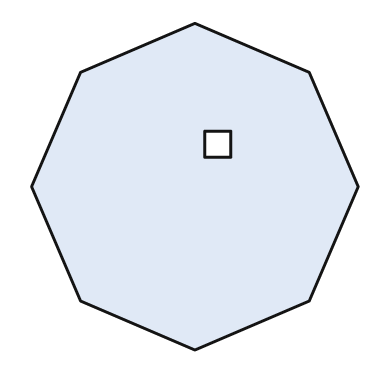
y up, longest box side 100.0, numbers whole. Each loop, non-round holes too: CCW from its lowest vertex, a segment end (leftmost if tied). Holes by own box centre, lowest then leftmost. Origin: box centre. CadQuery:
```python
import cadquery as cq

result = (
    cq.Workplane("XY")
    .moveTo(0.0, -50.0)
    .lineTo(35.0, -35.0)
    .lineTo(50.0, 0.0)
    .lineTo(35.0, 35.0)
    .lineTo(0.0, 50.0)
    .lineTo(-35.0, 35.0)
    .lineTo(-50.0, 0.0)
    .lineTo(-35.0, -35.0)
    .close()
    .moveTo(3.0, 9.0)
    .lineTo(11.0, 9.0)
    .lineTo(11.0, 17.0)
    .lineTo(3.0, 17.0)
    .close()
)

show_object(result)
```